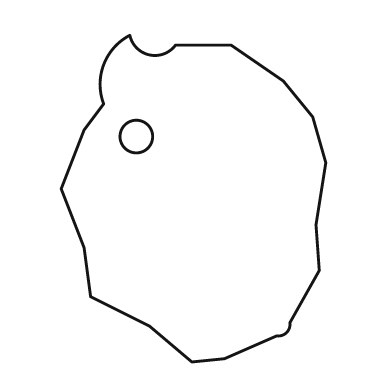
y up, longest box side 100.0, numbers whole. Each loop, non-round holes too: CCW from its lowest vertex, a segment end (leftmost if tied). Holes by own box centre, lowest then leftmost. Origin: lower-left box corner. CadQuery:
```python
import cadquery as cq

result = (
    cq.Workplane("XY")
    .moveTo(40.0, 0.0)
    .lineTo(50.0, 1.0)
    .lineTo(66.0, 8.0)
    .threePointArc((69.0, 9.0), (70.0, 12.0))
    .lineTo(79.0, 28.0)
    .lineTo(78.0, 42.0)
    .lineTo(81.0, 61.0)
    .lineTo(77.0, 75.0)
    .lineTo(68.0, 86.0)
    .lineTo(52.0, 97.0)
    .lineTo(35.0, 97.0)
    .threePointArc((27.0, 94.0), (21.0, 100.0))
    .threePointArc((13.0, 91.0), (13.0, 79.0))
    .lineTo(7.0, 71.0)
    .lineTo(0.0, 53.0)
    .lineTo(7.0, 35.0)
    .lineTo(9.0, 20.0)
    .lineTo(27.0, 11.0)
    .close()
    .moveTo(23.0, 69.0)
    .circle(5.0)
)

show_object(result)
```